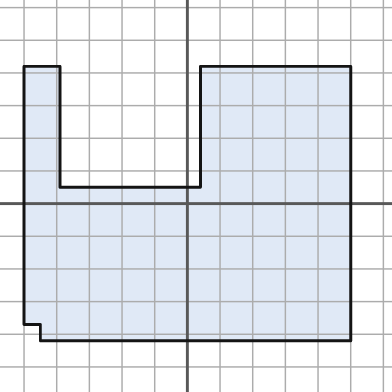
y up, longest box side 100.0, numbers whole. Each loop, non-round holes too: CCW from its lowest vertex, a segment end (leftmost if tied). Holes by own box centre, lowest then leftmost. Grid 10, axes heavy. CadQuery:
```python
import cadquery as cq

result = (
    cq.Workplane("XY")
    .moveTo(-45.0, -42.0)
    .lineTo(50.0, -42.0)
    .lineTo(50.0, 42.0)
    .lineTo(4.0, 42.0)
    .lineTo(4.0, 5.0)
    .lineTo(-39.0, 5.0)
    .lineTo(-39.0, 42.0)
    .lineTo(-50.0, 42.0)
    .lineTo(-50.0, -37.0)
    .lineTo(-45.0, -37.0)
    .close()
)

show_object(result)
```